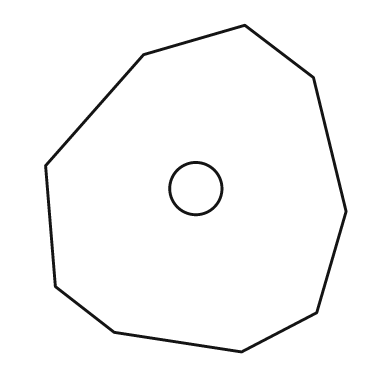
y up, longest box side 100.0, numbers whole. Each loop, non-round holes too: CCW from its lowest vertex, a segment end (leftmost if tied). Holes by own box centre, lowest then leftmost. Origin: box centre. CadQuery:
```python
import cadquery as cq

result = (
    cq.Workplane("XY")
    .moveTo(14.0, -50.0)
    .lineTo(37.0, -38.0)
    .lineTo(46.0, -7.0)
    .lineTo(36.0, 34.0)
    .lineTo(15.0, 50.0)
    .lineTo(-16.0, 41.0)
    .lineTo(-46.0, 7.0)
    .lineTo(-43.0, -30.0)
    .lineTo(-25.0, -44.0)
    .close()
    .moveTo(0.0, 0.0)
    .circle(8.0)
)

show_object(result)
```